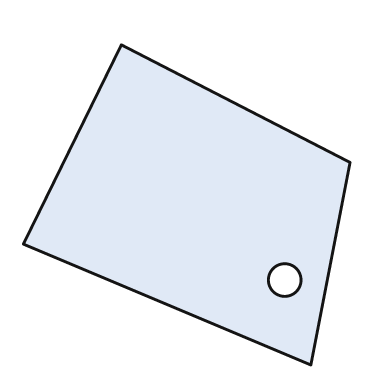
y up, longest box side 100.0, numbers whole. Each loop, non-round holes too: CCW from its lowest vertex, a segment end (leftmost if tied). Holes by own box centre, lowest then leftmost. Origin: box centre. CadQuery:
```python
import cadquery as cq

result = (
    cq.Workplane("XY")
    .moveTo(38.0, -49.0)
    .lineTo(50.0, 13.0)
    .lineTo(-20.0, 49.0)
    .lineTo(-50.0, -12.0)
    .close()
    .moveTo(30.0, -23.0)
    .circle(5.0)
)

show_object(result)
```